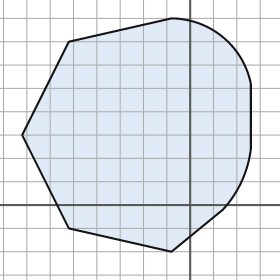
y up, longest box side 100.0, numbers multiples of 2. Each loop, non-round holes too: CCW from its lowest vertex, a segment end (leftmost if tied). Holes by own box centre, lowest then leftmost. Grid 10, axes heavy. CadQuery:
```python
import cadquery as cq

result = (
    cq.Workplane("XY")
    .moveTo(-8.0, -20.0)
    .lineTo(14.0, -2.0)
    .threePointArc((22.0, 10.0), (26.0, 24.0))
    .lineTo(26.0, 52.0)
    .threePointArc((14.0, 72.0), (-8.0, 80.0))
    .lineTo(-52.0, 70.0)
    .lineTo(-72.0, 30.0)
    .lineTo(-52.0, -10.0)
    .close()
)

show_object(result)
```